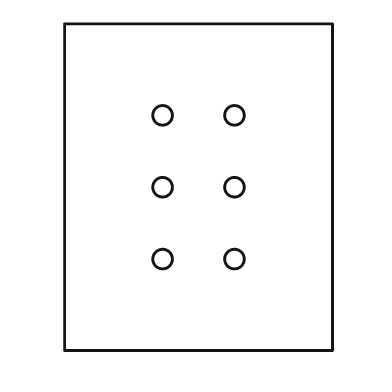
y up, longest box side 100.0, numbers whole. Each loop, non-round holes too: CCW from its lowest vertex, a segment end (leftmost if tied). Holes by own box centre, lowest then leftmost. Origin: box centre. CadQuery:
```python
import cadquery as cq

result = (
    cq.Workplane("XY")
    .moveTo(-41.0, -50.0)
    .lineTo(41.0, -50.0)
    .lineTo(41.0, 50.0)
    .lineTo(-41.0, 50.0)
    .close()
    .moveTo(-11.0, -22.0)
    .circle(3.0)
    .moveTo(11.0, -22.0)
    .circle(3.0)
    .moveTo(-11.0, 0.0)
    .circle(3.0)
    .moveTo(11.0, 0.0)
    .circle(3.0)
    .moveTo(-11.0, 22.0)
    .circle(3.0)
    .moveTo(11.0, 22.0)
    .circle(3.0)
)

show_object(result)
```